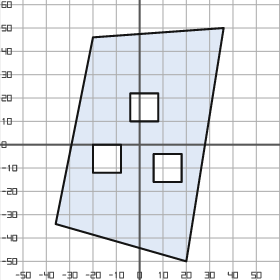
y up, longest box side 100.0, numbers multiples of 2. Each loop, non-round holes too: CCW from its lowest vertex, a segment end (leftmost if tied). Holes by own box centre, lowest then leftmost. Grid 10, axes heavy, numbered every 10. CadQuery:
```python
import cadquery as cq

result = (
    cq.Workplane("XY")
    .moveTo(20.0, -50.0)
    .lineTo(36.0, 50.0)
    .lineTo(-20.0, 46.0)
    .lineTo(-36.0, -34.0)
    .close()
    .moveTo(6.0, -16.0)
    .lineTo(18.0, -16.0)
    .lineTo(18.0, -4.0)
    .lineTo(6.0, -4.0)
    .close()
    .moveTo(-20.0, -12.0)
    .lineTo(-8.0, -12.0)
    .lineTo(-8.0, 0.0)
    .lineTo(-20.0, 0.0)
    .close()
    .moveTo(-4.0, 10.0)
    .lineTo(8.0, 10.0)
    .lineTo(8.0, 22.0)
    .lineTo(-4.0, 22.0)
    .close()
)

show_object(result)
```